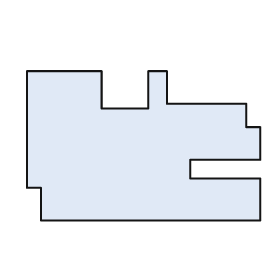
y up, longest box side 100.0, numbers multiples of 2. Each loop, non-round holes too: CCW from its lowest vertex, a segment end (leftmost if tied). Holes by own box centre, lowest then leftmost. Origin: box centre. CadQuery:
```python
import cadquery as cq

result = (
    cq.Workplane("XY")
    .moveTo(-44.0, -32.0)
    .lineTo(50.0, -32.0)
    .lineTo(50.0, -14.0)
    .lineTo(20.0, -14.0)
    .lineTo(20.0, -6.0)
    .lineTo(50.0, -6.0)
    .lineTo(50.0, 8.0)
    .lineTo(44.0, 8.0)
    .lineTo(44.0, 18.0)
    .lineTo(10.0, 18.0)
    .lineTo(10.0, 32.0)
    .lineTo(2.0, 32.0)
    .lineTo(2.0, 16.0)
    .lineTo(-18.0, 16.0)
    .lineTo(-18.0, 32.0)
    .lineTo(-50.0, 32.0)
    .lineTo(-50.0, -18.0)
    .lineTo(-44.0, -18.0)
    .close()
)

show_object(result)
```